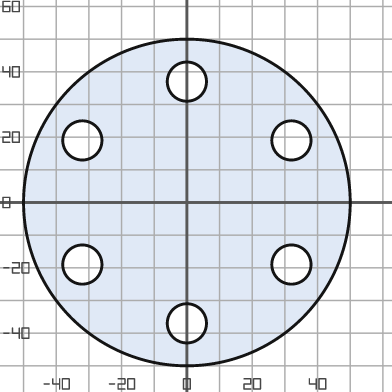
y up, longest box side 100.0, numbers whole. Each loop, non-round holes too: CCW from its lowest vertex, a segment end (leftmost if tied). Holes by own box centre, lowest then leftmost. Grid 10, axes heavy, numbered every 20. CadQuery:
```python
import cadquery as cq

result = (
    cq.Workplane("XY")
    .moveTo(0.0, 0.0)
    .circle(50.0)
    .moveTo(0.0, -37.0)
    .circle(6.0)
    .moveTo(-32.0, -19.0)
    .circle(6.0)
    .moveTo(32.0, -19.0)
    .circle(6.0)
    .moveTo(-32.0, 19.0)
    .circle(6.0)
    .moveTo(32.0, 19.0)
    .circle(6.0)
    .moveTo(0.0, 37.0)
    .circle(6.0)
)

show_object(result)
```